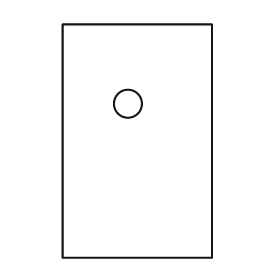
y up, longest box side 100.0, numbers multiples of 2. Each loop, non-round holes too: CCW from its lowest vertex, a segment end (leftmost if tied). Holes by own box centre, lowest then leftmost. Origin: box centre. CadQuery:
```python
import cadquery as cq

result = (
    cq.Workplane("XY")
    .moveTo(-32.0, -50.0)
    .lineTo(32.0, -50.0)
    .lineTo(32.0, 50.0)
    .lineTo(-32.0, 50.0)
    .close()
    .moveTo(-4.0, 16.0)
    .circle(6.0)
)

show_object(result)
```